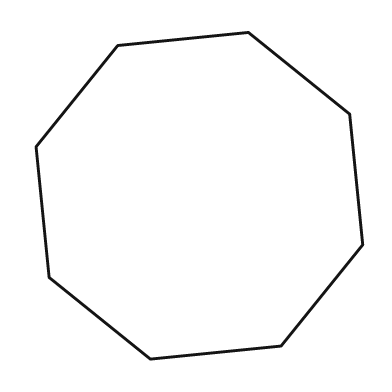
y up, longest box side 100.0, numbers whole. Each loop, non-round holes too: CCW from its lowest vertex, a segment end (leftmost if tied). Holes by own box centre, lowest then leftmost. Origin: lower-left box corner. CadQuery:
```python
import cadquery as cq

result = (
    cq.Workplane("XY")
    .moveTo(35.0, 0.0)
    .lineTo(75.0, 4.0)
    .lineTo(100.0, 35.0)
    .lineTo(96.0, 75.0)
    .lineTo(65.0, 100.0)
    .lineTo(25.0, 96.0)
    .lineTo(0.0, 65.0)
    .lineTo(4.0, 25.0)
    .close()
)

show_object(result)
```